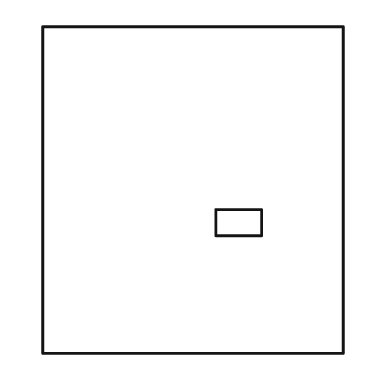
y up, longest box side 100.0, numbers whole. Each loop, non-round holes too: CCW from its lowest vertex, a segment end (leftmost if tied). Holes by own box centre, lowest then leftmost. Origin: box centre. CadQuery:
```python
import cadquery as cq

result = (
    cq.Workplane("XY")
    .moveTo(-46.0, -50.0)
    .lineTo(46.0, -50.0)
    .lineTo(46.0, 50.0)
    .lineTo(-46.0, 50.0)
    .close()
    .moveTo(7.0, -14.0)
    .lineTo(21.0, -14.0)
    .lineTo(21.0, -6.0)
    .lineTo(7.0, -6.0)
    .close()
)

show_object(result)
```